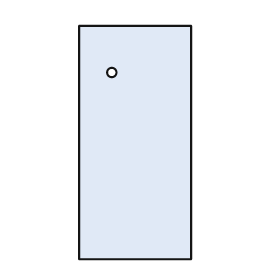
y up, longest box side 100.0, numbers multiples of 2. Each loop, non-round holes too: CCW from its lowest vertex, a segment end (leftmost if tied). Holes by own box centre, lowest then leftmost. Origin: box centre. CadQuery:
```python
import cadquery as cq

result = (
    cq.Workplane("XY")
    .moveTo(-24.0, -50.0)
    .lineTo(24.0, -50.0)
    .lineTo(24.0, 50.0)
    .lineTo(-24.0, 50.0)
    .close()
    .moveTo(-10.0, 30.0)
    .circle(2.0)
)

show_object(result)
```